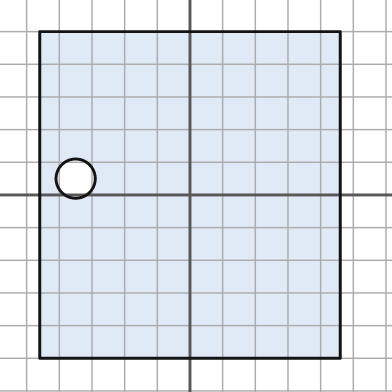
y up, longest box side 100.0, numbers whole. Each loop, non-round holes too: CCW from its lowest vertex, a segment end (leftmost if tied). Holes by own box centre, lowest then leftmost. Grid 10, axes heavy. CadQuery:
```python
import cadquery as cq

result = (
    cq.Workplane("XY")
    .moveTo(-46.0, -50.0)
    .lineTo(46.0, -50.0)
    .lineTo(46.0, 50.0)
    .lineTo(-46.0, 50.0)
    .close()
    .moveTo(-35.0, 5.0)
    .circle(6.0)
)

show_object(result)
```